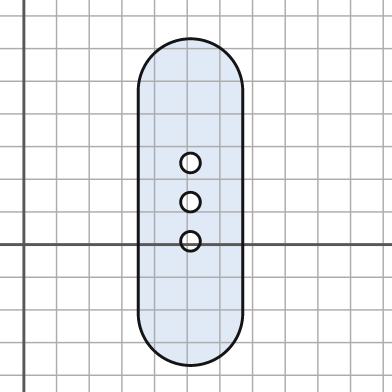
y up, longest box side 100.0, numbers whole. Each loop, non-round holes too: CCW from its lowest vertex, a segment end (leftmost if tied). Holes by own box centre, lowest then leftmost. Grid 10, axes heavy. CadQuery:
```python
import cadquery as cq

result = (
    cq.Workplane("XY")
    .moveTo(35.0, -21.0)
    .threePointArc((51.0, -37.0), (67.0, -21.0))
    .lineTo(67.0, 47.0)
    .threePointArc((51.0, 63.0), (35.0, 47.0))
    .close()
    .moveTo(51.0, 1.0)
    .circle(3.0)
    .moveTo(51.0, 13.0)
    .circle(3.0)
    .moveTo(51.0, 25.0)
    .circle(3.0)
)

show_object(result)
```